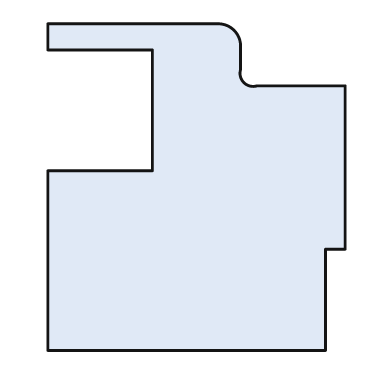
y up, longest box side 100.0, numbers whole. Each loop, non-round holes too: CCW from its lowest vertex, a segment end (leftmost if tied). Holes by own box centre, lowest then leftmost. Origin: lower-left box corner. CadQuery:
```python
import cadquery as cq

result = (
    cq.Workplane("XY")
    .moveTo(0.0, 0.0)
    .lineTo(85.0, 0.0)
    .lineTo(85.0, 31.0)
    .lineTo(91.0, 31.0)
    .lineTo(91.0, 81.0)
    .lineTo(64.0, 81.0)
    .threePointArc((60.0, 82.0), (59.0, 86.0))
    .lineTo(59.0, 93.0)
    .threePointArc((57.0, 98.0), (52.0, 100.0))
    .lineTo(0.0, 100.0)
    .lineTo(0.0, 92.0)
    .lineTo(32.0, 92.0)
    .lineTo(32.0, 55.0)
    .lineTo(0.0, 55.0)
    .close()
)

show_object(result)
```